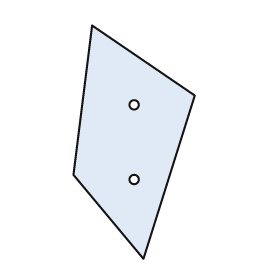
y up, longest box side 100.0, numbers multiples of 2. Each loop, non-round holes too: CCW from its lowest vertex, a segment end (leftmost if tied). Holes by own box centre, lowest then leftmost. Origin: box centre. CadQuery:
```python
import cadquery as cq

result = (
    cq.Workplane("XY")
    .moveTo(4.0, -50.0)
    .lineTo(26.0, 20.0)
    .lineTo(-18.0, 50.0)
    .lineTo(-26.0, -14.0)
    .close()
    .moveTo(0.0, -16.0)
    .circle(2.0)
    .moveTo(0.0, 16.0)
    .circle(2.0)
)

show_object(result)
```